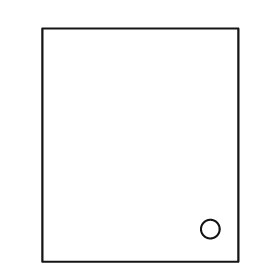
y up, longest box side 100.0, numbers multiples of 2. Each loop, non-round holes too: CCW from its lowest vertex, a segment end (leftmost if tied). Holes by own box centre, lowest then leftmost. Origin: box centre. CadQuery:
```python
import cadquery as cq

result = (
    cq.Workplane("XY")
    .moveTo(-42.0, -50.0)
    .lineTo(42.0, -50.0)
    .lineTo(42.0, 50.0)
    .lineTo(-42.0, 50.0)
    .close()
    .moveTo(30.0, -36.0)
    .circle(4.0)
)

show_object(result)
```